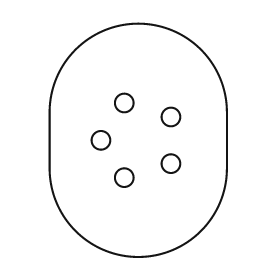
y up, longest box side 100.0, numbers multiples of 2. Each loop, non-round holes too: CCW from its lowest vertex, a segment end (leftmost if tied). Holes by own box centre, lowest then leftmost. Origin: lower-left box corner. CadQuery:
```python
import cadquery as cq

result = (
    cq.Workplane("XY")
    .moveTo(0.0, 38.0)
    .threePointArc((38.0, 0.0), (76.0, 38.0))
    .lineTo(76.0, 62.0)
    .threePointArc((38.0, 100.0), (0.0, 62.0))
    .close()
    .moveTo(32.0, 34.0)
    .circle(4.0)
    .moveTo(52.0, 40.0)
    .circle(4.0)
    .moveTo(22.0, 50.0)
    .circle(4.0)
    .moveTo(52.0, 60.0)
    .circle(4.0)
    .moveTo(32.0, 66.0)
    .circle(4.0)
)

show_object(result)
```